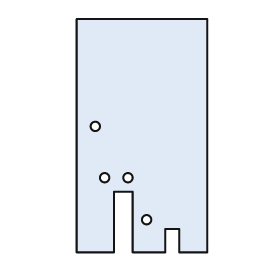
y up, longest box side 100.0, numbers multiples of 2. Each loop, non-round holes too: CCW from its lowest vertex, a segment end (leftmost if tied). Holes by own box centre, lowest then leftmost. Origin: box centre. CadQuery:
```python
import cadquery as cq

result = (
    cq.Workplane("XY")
    .moveTo(-28.0, -50.0)
    .lineTo(-12.0, -50.0)
    .lineTo(-12.0, -24.0)
    .lineTo(-4.0, -24.0)
    .lineTo(-4.0, -50.0)
    .lineTo(10.0, -50.0)
    .lineTo(10.0, -40.0)
    .lineTo(16.0, -40.0)
    .lineTo(16.0, -50.0)
    .lineTo(28.0, -50.0)
    .lineTo(28.0, 50.0)
    .lineTo(-28.0, 50.0)
    .close()
    .moveTo(2.0, -36.0)
    .circle(2.0)
    .moveTo(-16.0, -18.0)
    .circle(2.0)
    .moveTo(-6.0, -18.0)
    .circle(2.0)
    .moveTo(-20.0, 4.0)
    .circle(2.0)
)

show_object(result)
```